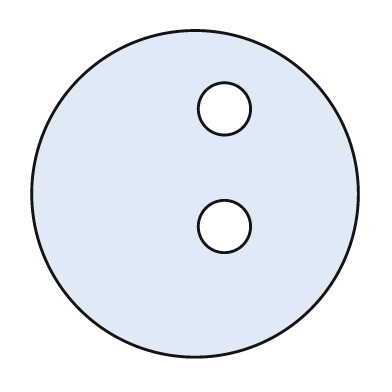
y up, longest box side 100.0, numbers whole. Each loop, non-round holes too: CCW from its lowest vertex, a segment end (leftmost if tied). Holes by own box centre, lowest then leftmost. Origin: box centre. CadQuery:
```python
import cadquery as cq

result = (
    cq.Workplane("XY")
    .moveTo(0.0, 0.0)
    .circle(50.0)
    .moveTo(9.0, -10.0)
    .circle(8.0)
    .moveTo(9.0, 26.0)
    .circle(8.0)
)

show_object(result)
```